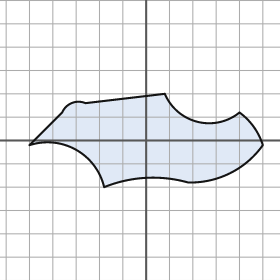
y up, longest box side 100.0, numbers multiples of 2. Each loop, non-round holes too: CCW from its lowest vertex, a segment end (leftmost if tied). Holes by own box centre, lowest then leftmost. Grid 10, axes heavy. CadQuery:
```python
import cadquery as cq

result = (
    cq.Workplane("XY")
    .moveTo(-18.0, -20.0)
    .threePointArc((0.0, -16.0), (18.0, -18.0))
    .threePointArc((36.0, -14.0), (50.0, -2.0))
    .threePointArc((46.0, 6.0), (40.0, 12.0))
    .threePointArc((22.0, 8.0), (8.0, 20.0))
    .lineTo(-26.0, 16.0)
    .threePointArc((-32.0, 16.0), (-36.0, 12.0))
    .lineTo(-50.0, -2.0)
    .threePointArc((-30.0, -4.0), (-18.0, -20.0))
    .close()
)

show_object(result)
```